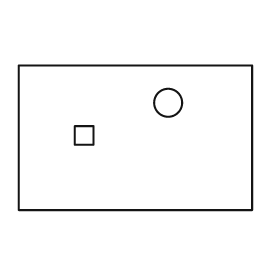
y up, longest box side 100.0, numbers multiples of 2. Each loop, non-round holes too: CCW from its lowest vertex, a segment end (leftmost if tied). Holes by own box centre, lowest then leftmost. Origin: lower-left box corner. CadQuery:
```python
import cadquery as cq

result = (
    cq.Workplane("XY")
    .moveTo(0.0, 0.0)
    .lineTo(100.0, 0.0)
    .lineTo(100.0, 62.0)
    .lineTo(0.0, 62.0)
    .close()
    .moveTo(24.0, 28.0)
    .lineTo(32.0, 28.0)
    .lineTo(32.0, 36.0)
    .lineTo(24.0, 36.0)
    .close()
    .moveTo(64.0, 46.0)
    .circle(6.0)
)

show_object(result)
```